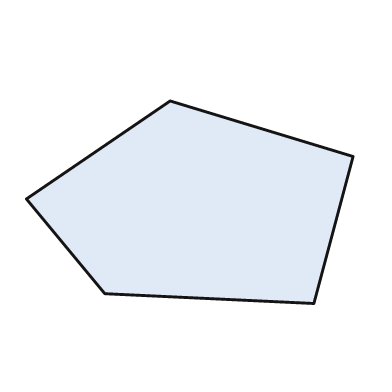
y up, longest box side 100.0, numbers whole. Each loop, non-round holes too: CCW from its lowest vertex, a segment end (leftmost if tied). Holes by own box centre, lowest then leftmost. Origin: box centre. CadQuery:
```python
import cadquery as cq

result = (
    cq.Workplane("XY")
    .moveTo(38.0, -31.0)
    .lineTo(50.0, 14.0)
    .lineTo(-6.0, 31.0)
    .lineTo(-50.0, 1.0)
    .lineTo(-26.0, -28.0)
    .close()
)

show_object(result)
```